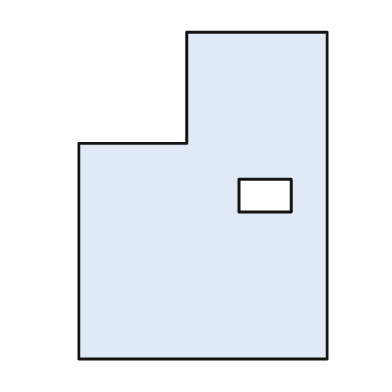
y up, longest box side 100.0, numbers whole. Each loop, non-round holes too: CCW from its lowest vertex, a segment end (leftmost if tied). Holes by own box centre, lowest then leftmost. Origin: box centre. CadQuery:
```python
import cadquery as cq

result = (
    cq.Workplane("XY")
    .moveTo(-38.0, -50.0)
    .lineTo(38.0, -50.0)
    .lineTo(38.0, 50.0)
    .lineTo(-5.0, 50.0)
    .lineTo(-5.0, 16.0)
    .lineTo(-38.0, 16.0)
    .close()
    .moveTo(11.0, -5.0)
    .lineTo(27.0, -5.0)
    .lineTo(27.0, 5.0)
    .lineTo(11.0, 5.0)
    .close()
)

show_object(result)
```